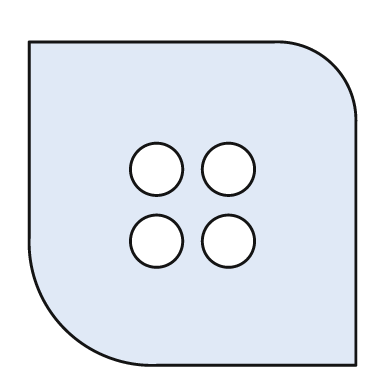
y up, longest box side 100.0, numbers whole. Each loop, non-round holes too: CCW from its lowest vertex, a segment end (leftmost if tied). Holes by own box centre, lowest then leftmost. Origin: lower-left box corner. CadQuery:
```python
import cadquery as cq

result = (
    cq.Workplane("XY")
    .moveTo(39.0, 0.0)
    .lineTo(100.0, 0.0)
    .lineTo(100.0, 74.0)
    .threePointArc((93.0, 92.0), (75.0, 99.0))
    .lineTo(0.0, 99.0)
    .lineTo(0.0, 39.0)
    .threePointArc((11.0, 11.0), (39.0, 0.0))
    .close()
    .moveTo(39.0, 38.0)
    .circle(8.0)
    .moveTo(61.0, 38.0)
    .circle(8.0)
    .moveTo(39.0, 60.0)
    .circle(8.0)
    .moveTo(61.0, 60.0)
    .circle(8.0)
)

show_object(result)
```